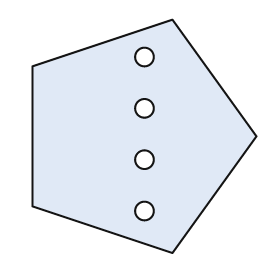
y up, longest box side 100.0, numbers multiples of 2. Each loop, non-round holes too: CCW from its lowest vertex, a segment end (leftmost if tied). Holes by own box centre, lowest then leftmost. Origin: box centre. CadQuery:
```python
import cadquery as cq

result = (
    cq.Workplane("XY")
    .moveTo(12.0, -50.0)
    .lineTo(48.0, 0.0)
    .lineTo(12.0, 50.0)
    .lineTo(-48.0, 30.0)
    .lineTo(-48.0, -30.0)
    .close()
    .moveTo(0.0, -32.0)
    .circle(4.0)
    .moveTo(0.0, -10.0)
    .circle(4.0)
    .moveTo(0.0, 12.0)
    .circle(4.0)
    .moveTo(0.0, 34.0)
    .circle(4.0)
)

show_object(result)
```